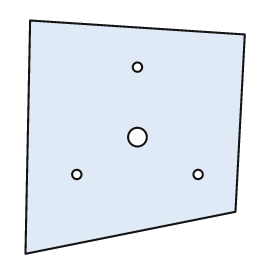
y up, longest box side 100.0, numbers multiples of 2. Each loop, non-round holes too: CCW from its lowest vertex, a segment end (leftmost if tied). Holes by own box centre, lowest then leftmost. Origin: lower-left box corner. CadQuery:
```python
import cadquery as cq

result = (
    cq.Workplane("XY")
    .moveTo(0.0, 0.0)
    .lineTo(90.0, 18.0)
    .lineTo(94.0, 94.0)
    .lineTo(2.0, 100.0)
    .close()
    .moveTo(22.0, 34.0)
    .circle(2.0)
    .moveTo(74.0, 34.0)
    .circle(2.0)
    .moveTo(48.0, 50.0)
    .circle(4.0)
    .moveTo(48.0, 80.0)
    .circle(2.0)
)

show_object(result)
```